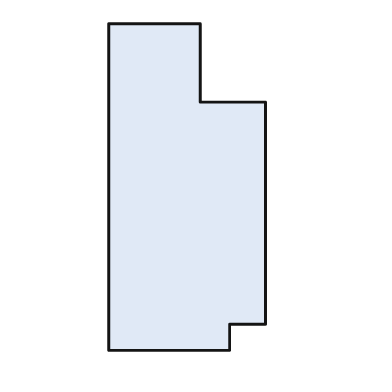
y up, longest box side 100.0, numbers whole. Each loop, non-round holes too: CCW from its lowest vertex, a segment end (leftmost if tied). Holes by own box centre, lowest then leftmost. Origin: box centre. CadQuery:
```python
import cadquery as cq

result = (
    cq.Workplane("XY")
    .moveTo(-24.0, -50.0)
    .lineTo(13.0, -50.0)
    .lineTo(13.0, -42.0)
    .lineTo(24.0, -42.0)
    .lineTo(24.0, 26.0)
    .lineTo(4.0, 26.0)
    .lineTo(4.0, 50.0)
    .lineTo(-24.0, 50.0)
    .close()
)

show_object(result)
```